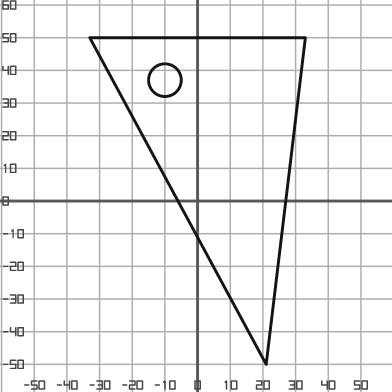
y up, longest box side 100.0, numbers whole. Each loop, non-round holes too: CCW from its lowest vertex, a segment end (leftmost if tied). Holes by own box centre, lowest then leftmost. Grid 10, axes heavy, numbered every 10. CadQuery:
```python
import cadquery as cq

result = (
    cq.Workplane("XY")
    .moveTo(21.0, -50.0)
    .lineTo(33.0, 50.0)
    .lineTo(-33.0, 50.0)
    .close()
    .moveTo(-10.0, 37.0)
    .circle(5.0)
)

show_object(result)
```